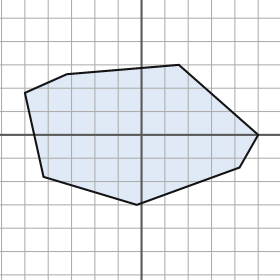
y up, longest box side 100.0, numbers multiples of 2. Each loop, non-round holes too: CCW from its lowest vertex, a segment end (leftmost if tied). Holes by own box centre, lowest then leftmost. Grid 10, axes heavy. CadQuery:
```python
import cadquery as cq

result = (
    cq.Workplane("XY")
    .moveTo(-2.0, -30.0)
    .lineTo(42.0, -14.0)
    .lineTo(50.0, 0.0)
    .lineTo(16.0, 30.0)
    .lineTo(-32.0, 26.0)
    .lineTo(-50.0, 18.0)
    .lineTo(-42.0, -18.0)
    .close()
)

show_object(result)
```